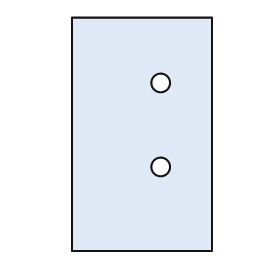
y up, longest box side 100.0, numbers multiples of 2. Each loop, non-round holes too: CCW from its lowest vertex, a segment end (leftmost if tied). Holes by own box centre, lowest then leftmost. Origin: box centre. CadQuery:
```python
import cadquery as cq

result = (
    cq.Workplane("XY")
    .moveTo(-30.0, -50.0)
    .lineTo(30.0, -50.0)
    .lineTo(30.0, 50.0)
    .lineTo(-30.0, 50.0)
    .close()
    .moveTo(8.0, -14.0)
    .circle(4.0)
    .moveTo(8.0, 22.0)
    .circle(4.0)
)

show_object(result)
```